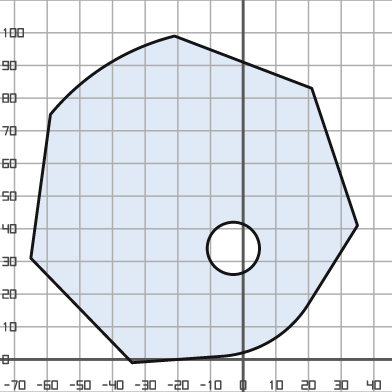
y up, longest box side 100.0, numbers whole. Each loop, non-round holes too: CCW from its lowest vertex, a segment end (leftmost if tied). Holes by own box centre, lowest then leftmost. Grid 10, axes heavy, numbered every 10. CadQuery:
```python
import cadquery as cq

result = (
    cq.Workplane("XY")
    .moveTo(-34.0, -1.0)
    .lineTo(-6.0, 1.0)
    .threePointArc((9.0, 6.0), (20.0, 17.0))
    .lineTo(35.0, 41.0)
    .lineTo(21.0, 83.0)
    .lineTo(-21.0, 99.0)
    .threePointArc((-42.0, 90.0), (-59.0, 75.0))
    .lineTo(-65.0, 31.0)
    .close()
    .moveTo(-3.0, 34.0)
    .circle(8.0)
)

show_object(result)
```